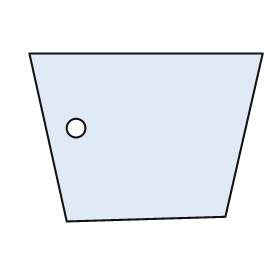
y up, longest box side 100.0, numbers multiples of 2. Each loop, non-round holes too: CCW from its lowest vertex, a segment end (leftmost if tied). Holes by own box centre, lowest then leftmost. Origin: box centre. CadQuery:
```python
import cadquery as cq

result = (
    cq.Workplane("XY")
    .moveTo(-34.0, -36.0)
    .lineTo(34.0, -34.0)
    .lineTo(50.0, 36.0)
    .lineTo(-50.0, 36.0)
    .close()
    .moveTo(-30.0, 4.0)
    .circle(4.0)
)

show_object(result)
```